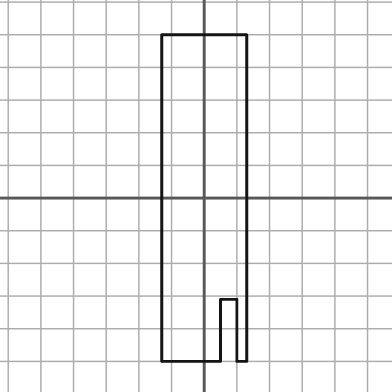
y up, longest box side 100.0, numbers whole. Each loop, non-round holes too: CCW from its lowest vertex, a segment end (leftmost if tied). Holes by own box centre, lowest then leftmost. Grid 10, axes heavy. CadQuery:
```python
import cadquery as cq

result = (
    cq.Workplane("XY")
    .moveTo(-13.0, -50.0)
    .lineTo(5.0, -50.0)
    .lineTo(5.0, -31.0)
    .lineTo(10.0, -31.0)
    .lineTo(10.0, -50.0)
    .lineTo(13.0, -50.0)
    .lineTo(13.0, 50.0)
    .lineTo(-13.0, 50.0)
    .close()
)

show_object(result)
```